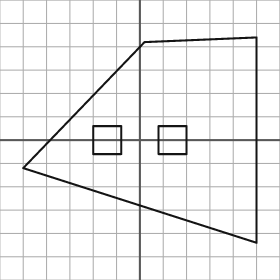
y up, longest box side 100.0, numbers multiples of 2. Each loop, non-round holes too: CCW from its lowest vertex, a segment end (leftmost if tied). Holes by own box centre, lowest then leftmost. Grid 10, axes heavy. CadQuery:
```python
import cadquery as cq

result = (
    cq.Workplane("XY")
    .moveTo(50.0, -44.0)
    .lineTo(50.0, 44.0)
    .lineTo(2.0, 42.0)
    .lineTo(-50.0, -12.0)
    .close()
    .moveTo(-20.0, -6.0)
    .lineTo(-8.0, -6.0)
    .lineTo(-8.0, 6.0)
    .lineTo(-20.0, 6.0)
    .close()
    .moveTo(8.0, -6.0)
    .lineTo(20.0, -6.0)
    .lineTo(20.0, 6.0)
    .lineTo(8.0, 6.0)
    .close()
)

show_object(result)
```